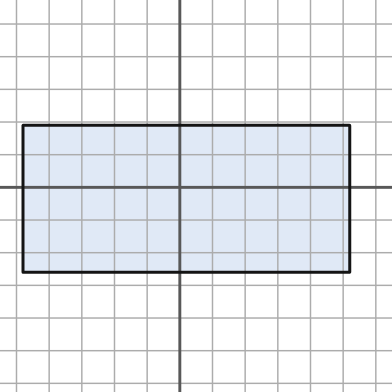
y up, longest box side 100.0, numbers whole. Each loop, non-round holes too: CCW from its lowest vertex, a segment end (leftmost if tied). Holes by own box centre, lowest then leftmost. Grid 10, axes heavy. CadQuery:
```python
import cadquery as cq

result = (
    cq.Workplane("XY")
    .moveTo(-48.0, -26.0)
    .lineTo(52.0, -26.0)
    .lineTo(52.0, 19.0)
    .lineTo(-48.0, 19.0)
    .close()
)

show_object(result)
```